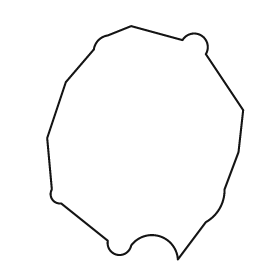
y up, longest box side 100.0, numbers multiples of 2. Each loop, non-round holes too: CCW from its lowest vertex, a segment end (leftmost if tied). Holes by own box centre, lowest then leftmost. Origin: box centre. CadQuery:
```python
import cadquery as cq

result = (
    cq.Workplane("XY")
    .moveTo(14.0, -50.0)
    .lineTo(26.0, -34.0)
    .threePointArc((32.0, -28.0), (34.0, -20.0))
    .lineTo(40.0, -4.0)
    .lineTo(42.0, 14.0)
    .lineTo(26.0, 38.0)
    .threePointArc((24.0, 46.0), (16.0, 44.0))
    .lineTo(-6.0, 50.0)
    .lineTo(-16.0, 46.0)
    .threePointArc((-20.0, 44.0), (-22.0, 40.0))
    .lineTo(-34.0, 26.0)
    .lineTo(-42.0, 2.0)
    .lineTo(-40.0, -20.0)
    .threePointArc((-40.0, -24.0), (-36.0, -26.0))
    .lineTo(-16.0, -42.0)
    .threePointArc((-12.0, -48.0), (-6.0, -44.0))
    .threePointArc((6.0, -40.0), (14.0, -50.0))
    .close()
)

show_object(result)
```